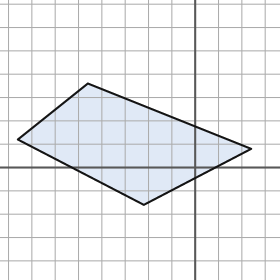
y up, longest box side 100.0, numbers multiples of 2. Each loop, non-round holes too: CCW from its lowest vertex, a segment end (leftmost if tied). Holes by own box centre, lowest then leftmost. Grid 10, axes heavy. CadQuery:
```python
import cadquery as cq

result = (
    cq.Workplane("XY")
    .moveTo(-22.0, -16.0)
    .lineTo(24.0, 8.0)
    .lineTo(-46.0, 36.0)
    .lineTo(-76.0, 12.0)
    .close()
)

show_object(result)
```